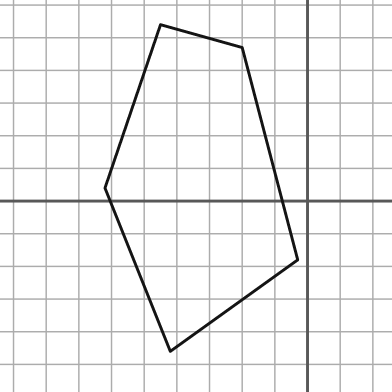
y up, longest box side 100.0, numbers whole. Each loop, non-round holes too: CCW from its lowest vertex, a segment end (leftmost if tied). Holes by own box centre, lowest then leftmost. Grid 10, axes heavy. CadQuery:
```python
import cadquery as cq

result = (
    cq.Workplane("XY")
    .moveTo(-42.0, -46.0)
    .lineTo(-3.0, -18.0)
    .lineTo(-20.0, 47.0)
    .lineTo(-45.0, 54.0)
    .lineTo(-62.0, 4.0)
    .close()
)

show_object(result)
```